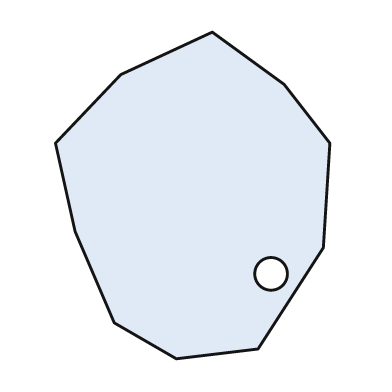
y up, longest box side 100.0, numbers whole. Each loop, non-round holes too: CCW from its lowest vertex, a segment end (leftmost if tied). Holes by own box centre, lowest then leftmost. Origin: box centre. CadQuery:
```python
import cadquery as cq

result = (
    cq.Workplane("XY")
    .moveTo(-5.0, -50.0)
    .lineTo(20.0, -47.0)
    .lineTo(40.0, -16.0)
    .lineTo(42.0, 16.0)
    .lineTo(28.0, 34.0)
    .lineTo(6.0, 50.0)
    .lineTo(-22.0, 37.0)
    .lineTo(-42.0, 16.0)
    .lineTo(-36.0, -11.0)
    .lineTo(-24.0, -39.0)
    .close()
    .moveTo(24.0, -24.0)
    .circle(5.0)
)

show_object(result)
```